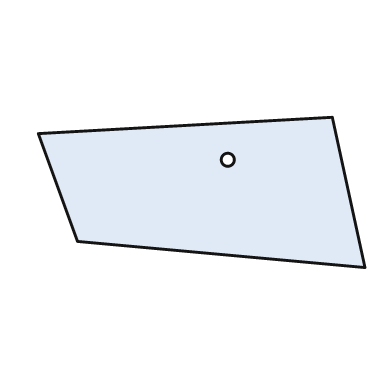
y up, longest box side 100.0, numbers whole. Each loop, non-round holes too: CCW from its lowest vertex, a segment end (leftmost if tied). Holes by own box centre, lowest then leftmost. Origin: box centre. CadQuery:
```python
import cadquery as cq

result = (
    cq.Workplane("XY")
    .moveTo(50.0, -23.0)
    .lineTo(40.0, 23.0)
    .lineTo(-50.0, 18.0)
    .lineTo(-38.0, -15.0)
    .close()
    .moveTo(8.0, 10.0)
    .circle(2.0)
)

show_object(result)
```